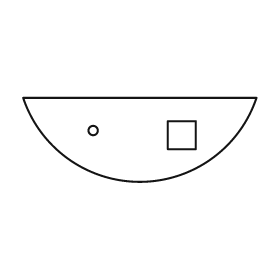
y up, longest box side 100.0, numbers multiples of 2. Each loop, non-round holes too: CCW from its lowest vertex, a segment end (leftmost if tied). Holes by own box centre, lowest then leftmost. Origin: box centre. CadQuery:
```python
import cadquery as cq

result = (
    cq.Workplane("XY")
    .moveTo(-50.0, 18.0)
    .threePointArc((0.0, -18.0), (50.0, 18.0))
    .close()
    .moveTo(12.0, -4.0)
    .lineTo(24.0, -4.0)
    .lineTo(24.0, 8.0)
    .lineTo(12.0, 8.0)
    .close()
    .moveTo(-20.0, 4.0)
    .circle(2.0)
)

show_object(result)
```